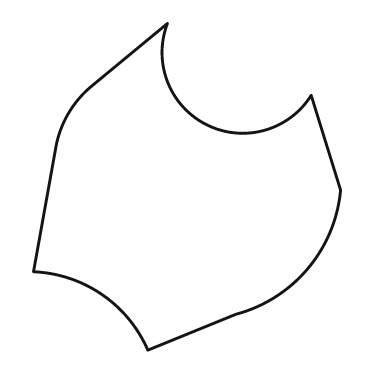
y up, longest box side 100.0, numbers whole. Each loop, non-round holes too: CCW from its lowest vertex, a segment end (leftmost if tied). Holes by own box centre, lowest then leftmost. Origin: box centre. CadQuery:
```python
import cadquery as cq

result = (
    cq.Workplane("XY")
    .moveTo(-12.0, -50.0)
    .lineTo(15.0, -39.0)
    .threePointArc((37.0, -25.0), (47.0, -1.0))
    .lineTo(38.0, 28.0)
    .threePointArc((6.0, 19.0), (-6.0, 50.0))
    .lineTo(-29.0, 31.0)
    .threePointArc((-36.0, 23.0), (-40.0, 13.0))
    .lineTo(-47.0, -26.0)
    .threePointArc((-26.0, -33.0), (-12.0, -50.0))
    .close()
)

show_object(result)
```